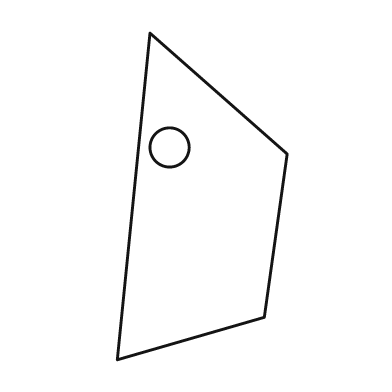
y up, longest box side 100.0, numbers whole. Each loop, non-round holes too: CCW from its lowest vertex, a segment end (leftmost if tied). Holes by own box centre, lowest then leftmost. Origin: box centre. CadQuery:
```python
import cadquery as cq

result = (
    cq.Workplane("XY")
    .moveTo(-26.0, -50.0)
    .lineTo(19.0, -37.0)
    .lineTo(26.0, 13.0)
    .lineTo(-16.0, 50.0)
    .close()
    .moveTo(-10.0, 15.0)
    .circle(6.0)
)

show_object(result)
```